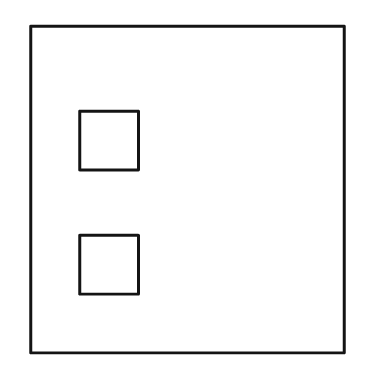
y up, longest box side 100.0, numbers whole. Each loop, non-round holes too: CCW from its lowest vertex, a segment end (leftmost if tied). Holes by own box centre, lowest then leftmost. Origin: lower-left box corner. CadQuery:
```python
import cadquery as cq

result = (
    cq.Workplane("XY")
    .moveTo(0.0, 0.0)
    .lineTo(96.0, 0.0)
    .lineTo(96.0, 100.0)
    .lineTo(0.0, 100.0)
    .close()
    .moveTo(15.0, 18.0)
    .lineTo(33.0, 18.0)
    .lineTo(33.0, 36.0)
    .lineTo(15.0, 36.0)
    .close()
    .moveTo(15.0, 56.0)
    .lineTo(33.0, 56.0)
    .lineTo(33.0, 74.0)
    .lineTo(15.0, 74.0)
    .close()
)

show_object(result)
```